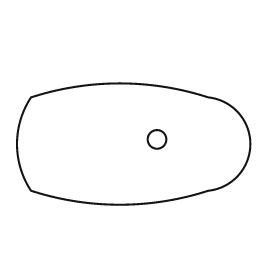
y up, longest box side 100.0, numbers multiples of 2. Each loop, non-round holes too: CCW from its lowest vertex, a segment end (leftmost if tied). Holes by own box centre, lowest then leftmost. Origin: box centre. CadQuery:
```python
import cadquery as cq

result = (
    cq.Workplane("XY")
    .moveTo(-44.0, -20.0)
    .threePointArc((-6.0, -26.0), (32.0, -20.0))
    .threePointArc((50.0, 0.0), (32.0, 20.0))
    .threePointArc((-6.0, 26.0), (-44.0, 20.0))
    .threePointArc((-50.0, 0.0), (-44.0, -20.0))
    .close()
    .moveTo(10.0, 2.0)
    .circle(4.0)
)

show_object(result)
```